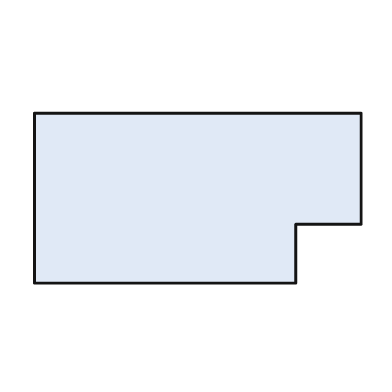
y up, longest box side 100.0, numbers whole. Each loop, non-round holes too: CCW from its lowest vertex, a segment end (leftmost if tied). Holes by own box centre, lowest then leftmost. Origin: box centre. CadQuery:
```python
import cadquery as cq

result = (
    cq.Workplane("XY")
    .moveTo(-50.0, -26.0)
    .lineTo(30.0, -26.0)
    .lineTo(30.0, -8.0)
    .lineTo(50.0, -8.0)
    .lineTo(50.0, 26.0)
    .lineTo(-50.0, 26.0)
    .close()
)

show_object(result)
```